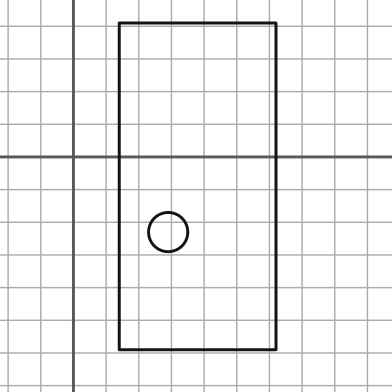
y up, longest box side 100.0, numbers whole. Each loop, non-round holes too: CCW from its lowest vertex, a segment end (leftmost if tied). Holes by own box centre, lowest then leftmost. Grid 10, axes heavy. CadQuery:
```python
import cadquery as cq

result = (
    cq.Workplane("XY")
    .moveTo(14.0, -59.0)
    .lineTo(62.0, -59.0)
    .lineTo(62.0, 41.0)
    .lineTo(14.0, 41.0)
    .close()
    .moveTo(29.0, -23.0)
    .circle(6.0)
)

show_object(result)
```